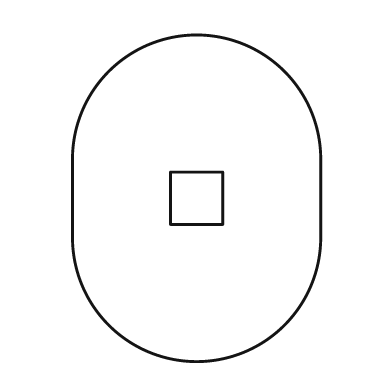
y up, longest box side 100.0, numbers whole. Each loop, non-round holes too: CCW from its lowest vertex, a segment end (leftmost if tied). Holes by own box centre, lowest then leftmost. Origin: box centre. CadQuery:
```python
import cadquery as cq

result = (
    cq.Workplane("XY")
    .moveTo(-38.0, -12.0)
    .threePointArc((0.0, -50.0), (38.0, -12.0))
    .lineTo(38.0, 12.0)
    .threePointArc((0.0, 50.0), (-38.0, 12.0))
    .close()
    .moveTo(-8.0, -8.0)
    .lineTo(8.0, -8.0)
    .lineTo(8.0, 8.0)
    .lineTo(-8.0, 8.0)
    .close()
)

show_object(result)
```